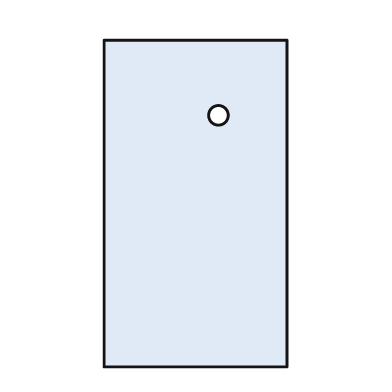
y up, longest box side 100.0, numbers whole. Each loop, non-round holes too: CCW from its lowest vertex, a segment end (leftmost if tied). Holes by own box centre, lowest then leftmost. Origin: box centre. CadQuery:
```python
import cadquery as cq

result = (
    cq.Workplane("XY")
    .moveTo(-28.0, -50.0)
    .lineTo(28.0, -50.0)
    .lineTo(28.0, 50.0)
    .lineTo(-28.0, 50.0)
    .close()
    .moveTo(7.0, 27.0)
    .circle(3.0)
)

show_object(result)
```